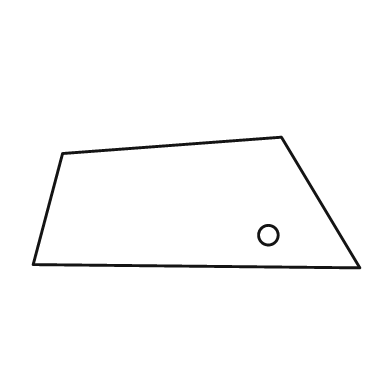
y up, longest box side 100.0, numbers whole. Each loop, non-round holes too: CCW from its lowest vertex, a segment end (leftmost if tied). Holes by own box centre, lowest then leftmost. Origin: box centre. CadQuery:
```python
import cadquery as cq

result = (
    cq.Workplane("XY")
    .moveTo(50.0, -20.0)
    .lineTo(26.0, 20.0)
    .lineTo(-41.0, 15.0)
    .lineTo(-50.0, -19.0)
    .close()
    .moveTo(22.0, -10.0)
    .circle(3.0)
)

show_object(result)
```